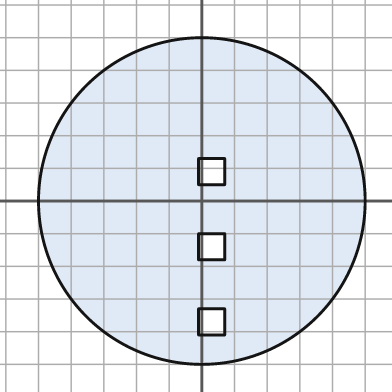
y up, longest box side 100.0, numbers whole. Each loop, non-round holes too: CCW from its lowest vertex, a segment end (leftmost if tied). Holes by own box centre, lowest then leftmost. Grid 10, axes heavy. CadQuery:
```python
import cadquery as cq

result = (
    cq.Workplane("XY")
    .moveTo(0.0, 0.0)
    .circle(50.0)
    .moveTo(-1.0, -41.0)
    .lineTo(7.0, -41.0)
    .lineTo(7.0, -33.0)
    .lineTo(-1.0, -33.0)
    .close()
    .moveTo(-1.0, -18.0)
    .lineTo(7.0, -18.0)
    .lineTo(7.0, -10.0)
    .lineTo(-1.0, -10.0)
    .close()
    .moveTo(-1.0, 5.0)
    .lineTo(7.0, 5.0)
    .lineTo(7.0, 13.0)
    .lineTo(-1.0, 13.0)
    .close()
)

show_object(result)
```